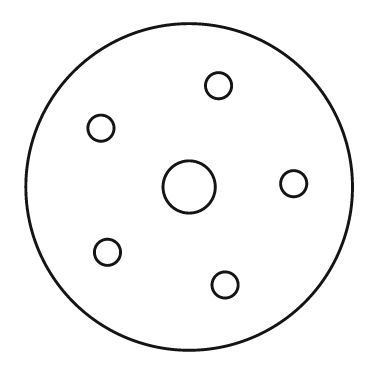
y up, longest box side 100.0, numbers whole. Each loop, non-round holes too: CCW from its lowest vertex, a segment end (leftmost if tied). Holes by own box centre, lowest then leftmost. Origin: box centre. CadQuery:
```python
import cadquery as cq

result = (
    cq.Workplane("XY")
    .moveTo(0.0, 0.0)
    .circle(50.0)
    .moveTo(11.0, -30.0)
    .circle(4.0)
    .moveTo(-25.0, -20.0)
    .circle(4.0)
    .moveTo(0.0, 0.0)
    .circle(8.0)
    .moveTo(32.0, 1.0)
    .circle(4.0)
    .moveTo(-27.0, 18.0)
    .circle(4.0)
    .moveTo(9.0, 31.0)
    .circle(4.0)
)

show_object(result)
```